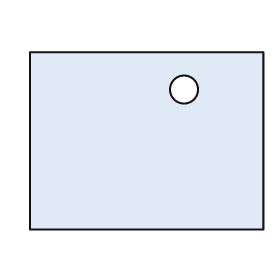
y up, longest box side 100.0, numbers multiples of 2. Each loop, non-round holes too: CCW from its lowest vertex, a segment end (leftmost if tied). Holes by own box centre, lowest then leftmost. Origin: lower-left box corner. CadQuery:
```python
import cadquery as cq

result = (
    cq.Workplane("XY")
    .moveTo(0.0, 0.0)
    .lineTo(100.0, 0.0)
    .lineTo(100.0, 76.0)
    .lineTo(0.0, 76.0)
    .close()
    .moveTo(66.0, 60.0)
    .circle(6.0)
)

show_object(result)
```